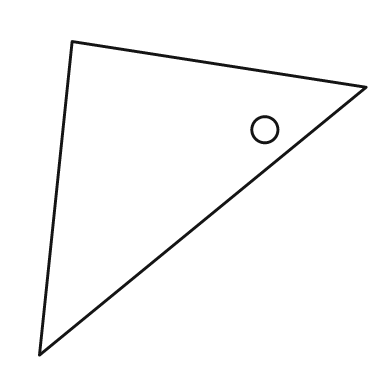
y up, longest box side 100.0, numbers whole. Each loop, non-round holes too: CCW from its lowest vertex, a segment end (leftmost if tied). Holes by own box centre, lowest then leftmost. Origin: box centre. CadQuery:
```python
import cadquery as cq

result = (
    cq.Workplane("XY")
    .moveTo(-50.0, -48.0)
    .lineTo(50.0, 34.0)
    .lineTo(-40.0, 48.0)
    .close()
    .moveTo(19.0, 21.0)
    .circle(4.0)
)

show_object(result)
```